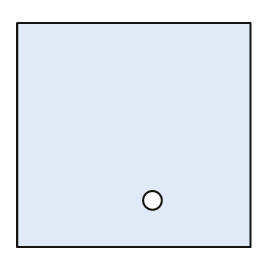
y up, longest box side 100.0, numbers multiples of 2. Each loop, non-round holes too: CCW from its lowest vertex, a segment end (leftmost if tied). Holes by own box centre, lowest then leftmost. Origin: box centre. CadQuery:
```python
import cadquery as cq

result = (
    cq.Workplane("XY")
    .moveTo(-50.0, -48.0)
    .lineTo(50.0, -48.0)
    .lineTo(50.0, 48.0)
    .lineTo(-50.0, 48.0)
    .close()
    .moveTo(8.0, -28.0)
    .circle(4.0)
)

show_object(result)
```